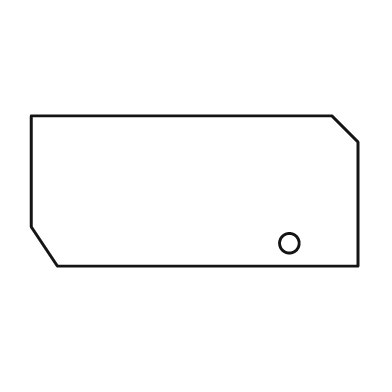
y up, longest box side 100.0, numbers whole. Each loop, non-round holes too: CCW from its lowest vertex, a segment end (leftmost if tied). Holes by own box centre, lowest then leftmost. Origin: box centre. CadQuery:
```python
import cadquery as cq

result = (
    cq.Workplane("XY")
    .moveTo(-42.0, -23.0)
    .lineTo(50.0, -23.0)
    .lineTo(50.0, 15.0)
    .lineTo(42.0, 23.0)
    .lineTo(-50.0, 23.0)
    .lineTo(-50.0, -11.0)
    .close()
    .moveTo(29.0, -16.0)
    .circle(3.0)
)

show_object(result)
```